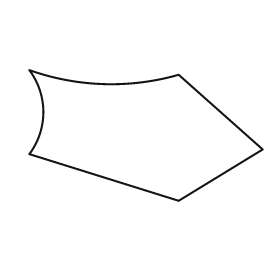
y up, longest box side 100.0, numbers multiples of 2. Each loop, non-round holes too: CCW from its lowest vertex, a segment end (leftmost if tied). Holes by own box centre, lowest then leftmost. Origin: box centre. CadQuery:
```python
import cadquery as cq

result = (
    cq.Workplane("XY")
    .moveTo(14.0, -28.0)
    .lineTo(50.0, -6.0)
    .lineTo(14.0, 26.0)
    .threePointArc((-18.0, 22.0), (-50.0, 28.0))
    .threePointArc((-44.0, 10.0), (-50.0, -8.0))
    .close()
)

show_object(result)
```